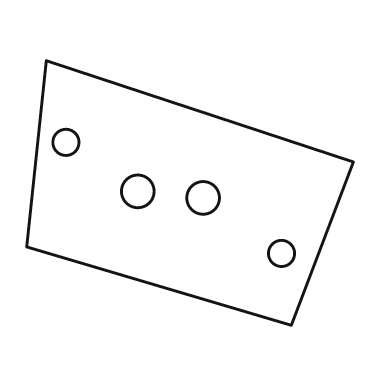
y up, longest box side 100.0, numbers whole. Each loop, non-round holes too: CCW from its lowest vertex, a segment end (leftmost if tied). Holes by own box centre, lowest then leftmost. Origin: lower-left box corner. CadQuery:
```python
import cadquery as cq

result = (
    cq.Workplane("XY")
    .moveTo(81.0, 0.0)
    .lineTo(100.0, 50.0)
    .lineTo(6.0, 81.0)
    .lineTo(0.0, 24.0)
    .close()
    .moveTo(78.0, 22.0)
    .circle(4.0)
    .moveTo(54.0, 39.0)
    .circle(5.0)
    .moveTo(34.0, 41.0)
    .circle(5.0)
    .moveTo(12.0, 56.0)
    .circle(4.0)
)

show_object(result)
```